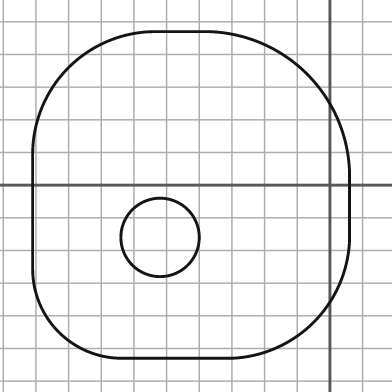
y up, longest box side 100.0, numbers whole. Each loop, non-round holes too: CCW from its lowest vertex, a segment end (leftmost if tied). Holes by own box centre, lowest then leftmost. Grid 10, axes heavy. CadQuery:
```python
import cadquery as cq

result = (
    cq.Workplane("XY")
    .moveTo(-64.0, -53.0)
    .lineTo(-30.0, -53.0)
    .threePointArc((-5.0, -42.0), (6.0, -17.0))
    .lineTo(6.0, 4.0)
    .threePointArc((-7.0, 34.0), (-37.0, 47.0))
    .lineTo(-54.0, 47.0)
    .threePointArc((-80.0, 36.0), (-91.0, 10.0))
    .lineTo(-91.0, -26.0)
    .threePointArc((-83.0, -45.0), (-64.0, -53.0))
    .close()
    .moveTo(-52.0, -16.0)
    .circle(12.0)
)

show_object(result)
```